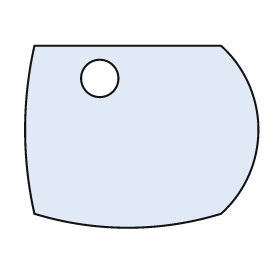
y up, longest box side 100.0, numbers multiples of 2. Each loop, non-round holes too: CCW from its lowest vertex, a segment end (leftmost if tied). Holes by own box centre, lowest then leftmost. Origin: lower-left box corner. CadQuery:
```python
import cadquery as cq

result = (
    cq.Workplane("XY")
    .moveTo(4.0, 6.0)
    .threePointArc((44.0, 0.0), (84.0, 6.0))
    .threePointArc((100.0, 42.0), (84.0, 78.0))
    .lineTo(4.0, 78.0)
    .threePointArc((0.0, 42.0), (4.0, 6.0))
    .close()
    .moveTo(32.0, 64.0)
    .circle(8.0)
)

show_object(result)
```